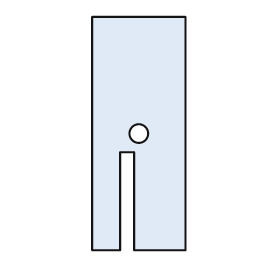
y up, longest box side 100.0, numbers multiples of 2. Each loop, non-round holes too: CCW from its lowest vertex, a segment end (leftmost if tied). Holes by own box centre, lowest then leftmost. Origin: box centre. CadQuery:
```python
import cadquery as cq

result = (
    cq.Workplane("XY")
    .moveTo(-20.0, -50.0)
    .lineTo(-8.0, -50.0)
    .lineTo(-8.0, -8.0)
    .lineTo(-2.0, -8.0)
    .lineTo(-2.0, -50.0)
    .lineTo(20.0, -50.0)
    .lineTo(20.0, 50.0)
    .lineTo(-20.0, 50.0)
    .close()
    .moveTo(0.0, 0.0)
    .circle(4.0)
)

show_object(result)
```